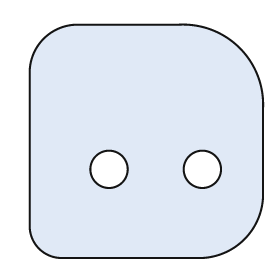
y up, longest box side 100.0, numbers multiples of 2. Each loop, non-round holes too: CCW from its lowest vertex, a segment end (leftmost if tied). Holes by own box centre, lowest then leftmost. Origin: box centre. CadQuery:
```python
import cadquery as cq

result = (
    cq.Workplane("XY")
    .moveTo(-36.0, -50.0)
    .lineTo(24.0, -50.0)
    .threePointArc((42.0, -42.0), (50.0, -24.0))
    .lineTo(50.0, 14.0)
    .threePointArc((40.0, 40.0), (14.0, 50.0))
    .lineTo(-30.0, 50.0)
    .threePointArc((-44.0, 44.0), (-50.0, 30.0))
    .lineTo(-50.0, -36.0)
    .threePointArc((-46.0, -46.0), (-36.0, -50.0))
    .close()
    .moveTo(-16.0, -12.0)
    .circle(8.0)
    .moveTo(24.0, -12.0)
    .circle(8.0)
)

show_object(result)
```